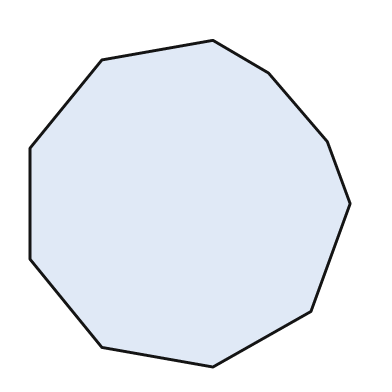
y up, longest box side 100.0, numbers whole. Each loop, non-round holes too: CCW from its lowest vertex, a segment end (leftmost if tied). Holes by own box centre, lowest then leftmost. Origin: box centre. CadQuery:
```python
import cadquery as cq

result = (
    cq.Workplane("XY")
    .moveTo(7.0, -50.0)
    .lineTo(37.0, -33.0)
    .lineTo(49.0, 0.0)
    .lineTo(42.0, 19.0)
    .lineTo(24.0, 40.0)
    .lineTo(7.0, 50.0)
    .lineTo(-27.0, 44.0)
    .lineTo(-49.0, 17.0)
    .lineTo(-49.0, -17.0)
    .lineTo(-27.0, -44.0)
    .close()
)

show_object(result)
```